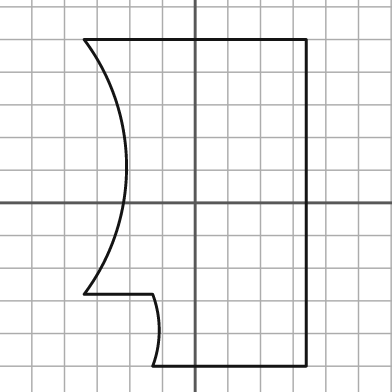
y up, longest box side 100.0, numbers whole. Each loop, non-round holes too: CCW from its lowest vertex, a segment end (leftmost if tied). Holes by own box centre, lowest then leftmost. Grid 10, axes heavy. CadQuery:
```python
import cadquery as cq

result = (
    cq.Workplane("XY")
    .moveTo(-13.0, -50.0)
    .lineTo(34.0, -50.0)
    .lineTo(34.0, 50.0)
    .lineTo(-34.0, 50.0)
    .threePointArc((-21.0, 11.0), (-34.0, -28.0))
    .lineTo(-13.0, -28.0)
    .threePointArc((-11.0, -39.0), (-13.0, -50.0))
    .close()
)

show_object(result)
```